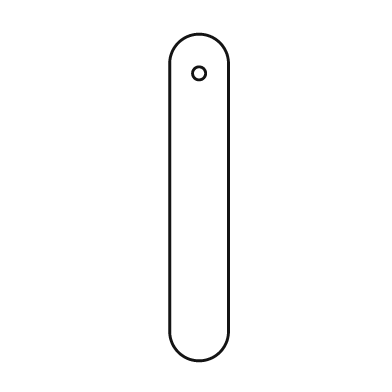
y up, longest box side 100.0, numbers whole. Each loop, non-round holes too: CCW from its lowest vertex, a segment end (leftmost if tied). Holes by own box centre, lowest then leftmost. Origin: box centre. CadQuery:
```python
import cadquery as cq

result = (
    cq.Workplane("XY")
    .moveTo(-9.0, -41.0)
    .threePointArc((0.0, -50.0), (9.0, -41.0))
    .lineTo(9.0, 41.0)
    .threePointArc((0.0, 50.0), (-9.0, 41.0))
    .close()
    .moveTo(0.0, 38.0)
    .circle(2.0)
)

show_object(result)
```